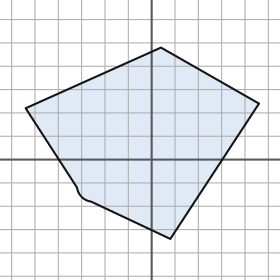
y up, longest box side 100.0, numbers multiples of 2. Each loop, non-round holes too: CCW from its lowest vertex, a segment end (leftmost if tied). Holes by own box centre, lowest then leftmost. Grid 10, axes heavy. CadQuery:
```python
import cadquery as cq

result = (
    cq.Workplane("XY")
    .moveTo(8.0, -34.0)
    .lineTo(46.0, 24.0)
    .lineTo(4.0, 48.0)
    .lineTo(-54.0, 22.0)
    .lineTo(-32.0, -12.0)
    .threePointArc((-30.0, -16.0), (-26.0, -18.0))
    .close()
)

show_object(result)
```